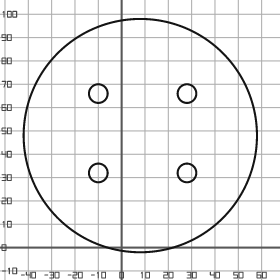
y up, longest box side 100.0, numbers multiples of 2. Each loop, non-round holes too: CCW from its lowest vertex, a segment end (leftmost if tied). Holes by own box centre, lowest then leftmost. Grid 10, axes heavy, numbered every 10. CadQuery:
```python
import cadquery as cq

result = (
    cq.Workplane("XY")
    .moveTo(8.0, 48.0)
    .circle(50.0)
    .moveTo(-10.0, 32.0)
    .circle(4.0)
    .moveTo(28.0, 32.0)
    .circle(4.0)
    .moveTo(-10.0, 66.0)
    .circle(4.0)
    .moveTo(28.0, 66.0)
    .circle(4.0)
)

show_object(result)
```